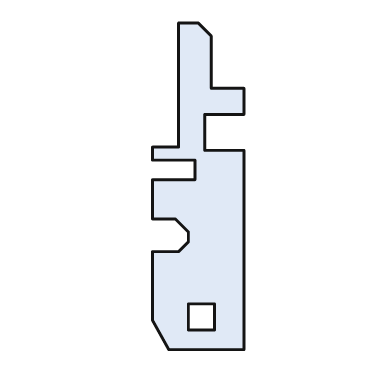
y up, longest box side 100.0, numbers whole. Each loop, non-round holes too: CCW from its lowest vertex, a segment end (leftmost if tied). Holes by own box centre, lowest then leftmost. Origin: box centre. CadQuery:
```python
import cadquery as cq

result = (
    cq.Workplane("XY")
    .moveTo(-9.0, -50.0)
    .lineTo(14.0, -50.0)
    .lineTo(14.0, 11.0)
    .lineTo(2.0, 11.0)
    .lineTo(2.0, 22.0)
    .lineTo(14.0, 22.0)
    .lineTo(14.0, 30.0)
    .lineTo(4.0, 30.0)
    .lineTo(4.0, 46.0)
    .lineTo(0.0, 50.0)
    .lineTo(-6.0, 50.0)
    .lineTo(-6.0, 12.0)
    .lineTo(-14.0, 12.0)
    .lineTo(-14.0, 8.0)
    .lineTo(-1.0, 8.0)
    .lineTo(-1.0, 2.0)
    .lineTo(-14.0, 2.0)
    .lineTo(-14.0, -10.0)
    .lineTo(-7.0, -10.0)
    .lineTo(-3.0, -14.0)
    .lineTo(-3.0, -17.0)
    .lineTo(-6.0, -20.0)
    .lineTo(-14.0, -20.0)
    .lineTo(-14.0, -41.0)
    .close()
    .moveTo(-3.0, -44.0)
    .lineTo(5.0, -44.0)
    .lineTo(5.0, -36.0)
    .lineTo(-3.0, -36.0)
    .close()
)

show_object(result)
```